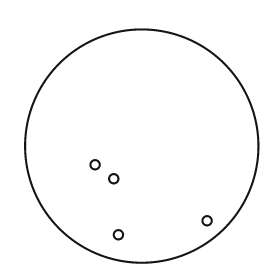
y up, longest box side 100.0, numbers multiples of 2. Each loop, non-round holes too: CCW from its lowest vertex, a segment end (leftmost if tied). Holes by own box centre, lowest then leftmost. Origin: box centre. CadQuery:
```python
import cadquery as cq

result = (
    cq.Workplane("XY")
    .moveTo(0.0, 0.0)
    .circle(50.0)
    .moveTo(-10.0, -38.0)
    .circle(2.0)
    .moveTo(28.0, -32.0)
    .circle(2.0)
    .moveTo(-12.0, -14.0)
    .circle(2.0)
    .moveTo(-20.0, -8.0)
    .circle(2.0)
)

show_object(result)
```